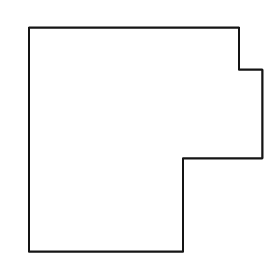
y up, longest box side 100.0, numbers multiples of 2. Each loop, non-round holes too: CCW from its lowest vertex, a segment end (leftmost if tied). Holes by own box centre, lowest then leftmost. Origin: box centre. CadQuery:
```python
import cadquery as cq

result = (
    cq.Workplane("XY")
    .moveTo(-50.0, -48.0)
    .lineTo(16.0, -48.0)
    .lineTo(16.0, -8.0)
    .lineTo(50.0, -8.0)
    .lineTo(50.0, 30.0)
    .lineTo(40.0, 30.0)
    .lineTo(40.0, 48.0)
    .lineTo(-50.0, 48.0)
    .close()
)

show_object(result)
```